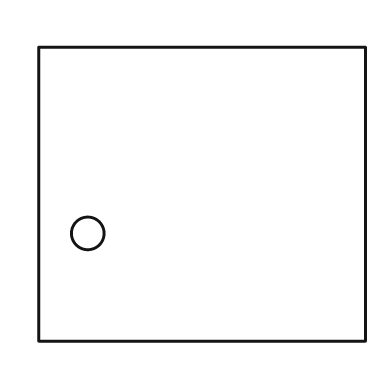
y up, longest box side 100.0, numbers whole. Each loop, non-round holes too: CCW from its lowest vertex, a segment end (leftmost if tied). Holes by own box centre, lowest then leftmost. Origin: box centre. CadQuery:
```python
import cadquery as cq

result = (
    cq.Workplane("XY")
    .moveTo(-50.0, -45.0)
    .lineTo(50.0, -45.0)
    .lineTo(50.0, 45.0)
    .lineTo(-50.0, 45.0)
    .close()
    .moveTo(-35.0, -12.0)
    .circle(5.0)
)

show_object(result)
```